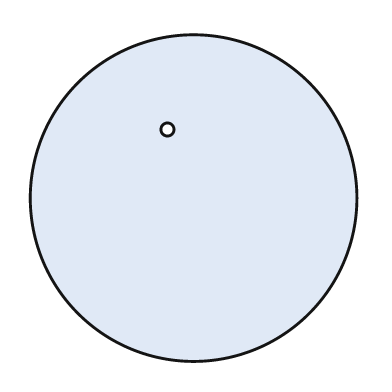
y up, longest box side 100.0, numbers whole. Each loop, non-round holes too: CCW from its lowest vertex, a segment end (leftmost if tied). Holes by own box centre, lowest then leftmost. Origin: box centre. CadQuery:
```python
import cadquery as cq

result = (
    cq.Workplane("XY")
    .moveTo(0.0, 0.0)
    .circle(50.0)
    .moveTo(-8.0, 21.0)
    .circle(2.0)
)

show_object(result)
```